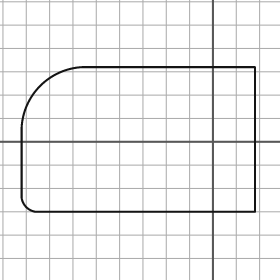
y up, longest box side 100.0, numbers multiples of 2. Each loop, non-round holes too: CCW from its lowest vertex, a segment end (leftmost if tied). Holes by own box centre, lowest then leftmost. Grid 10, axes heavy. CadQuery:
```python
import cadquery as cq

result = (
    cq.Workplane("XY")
    .moveTo(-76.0, -30.0)
    .lineTo(18.0, -30.0)
    .lineTo(18.0, 32.0)
    .lineTo(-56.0, 32.0)
    .threePointArc((-74.0, 24.0), (-82.0, 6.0))
    .lineTo(-82.0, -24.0)
    .threePointArc((-80.0, -28.0), (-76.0, -30.0))
    .close()
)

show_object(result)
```